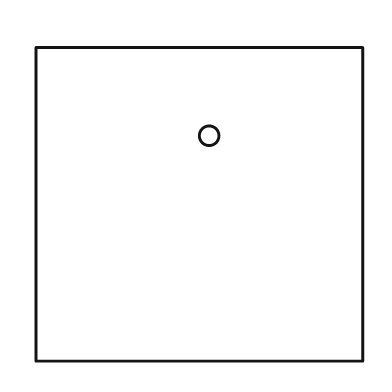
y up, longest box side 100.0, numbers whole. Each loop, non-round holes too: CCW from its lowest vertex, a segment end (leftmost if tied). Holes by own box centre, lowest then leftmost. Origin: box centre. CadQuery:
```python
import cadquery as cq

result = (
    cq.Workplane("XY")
    .moveTo(-50.0, -48.0)
    .lineTo(50.0, -48.0)
    .lineTo(50.0, 48.0)
    .lineTo(-50.0, 48.0)
    .close()
    .moveTo(3.0, 21.0)
    .circle(3.0)
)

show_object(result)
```